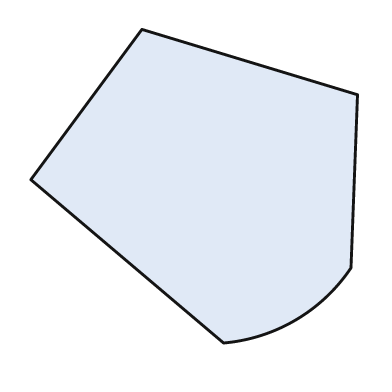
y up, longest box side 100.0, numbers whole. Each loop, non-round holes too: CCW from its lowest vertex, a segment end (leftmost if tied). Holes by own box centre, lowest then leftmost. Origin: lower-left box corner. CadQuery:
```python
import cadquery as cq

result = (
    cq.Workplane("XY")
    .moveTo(59.0, 0.0)
    .threePointArc((81.0, 7.0), (98.0, 23.0))
    .lineTo(100.0, 76.0)
    .lineTo(34.0, 96.0)
    .lineTo(0.0, 50.0)
    .close()
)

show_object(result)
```